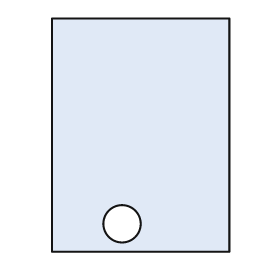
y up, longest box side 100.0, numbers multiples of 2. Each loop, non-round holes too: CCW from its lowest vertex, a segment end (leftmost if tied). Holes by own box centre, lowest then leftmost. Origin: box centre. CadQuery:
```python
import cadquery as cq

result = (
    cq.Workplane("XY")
    .moveTo(-38.0, -50.0)
    .lineTo(38.0, -50.0)
    .lineTo(38.0, 50.0)
    .lineTo(-38.0, 50.0)
    .close()
    .moveTo(-8.0, -38.0)
    .circle(8.0)
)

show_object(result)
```